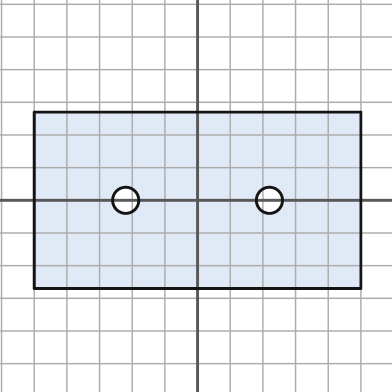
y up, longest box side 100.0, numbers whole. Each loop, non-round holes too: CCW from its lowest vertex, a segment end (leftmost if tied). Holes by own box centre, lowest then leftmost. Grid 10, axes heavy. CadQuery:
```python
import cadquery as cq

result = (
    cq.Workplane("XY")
    .moveTo(-50.0, -27.0)
    .lineTo(50.0, -27.0)
    .lineTo(50.0, 27.0)
    .lineTo(-50.0, 27.0)
    .close()
    .moveTo(-22.0, 0.0)
    .circle(4.0)
    .moveTo(22.0, 0.0)
    .circle(4.0)
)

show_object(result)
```